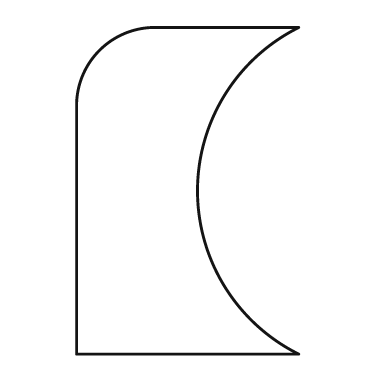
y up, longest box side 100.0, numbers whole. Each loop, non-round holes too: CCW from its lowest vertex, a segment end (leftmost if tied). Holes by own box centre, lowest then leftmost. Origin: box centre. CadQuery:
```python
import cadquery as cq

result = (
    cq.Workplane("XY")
    .moveTo(-34.0, -50.0)
    .lineTo(34.0, -50.0)
    .threePointArc((3.0, 0.0), (34.0, 50.0))
    .lineTo(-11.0, 50.0)
    .threePointArc((-27.0, 43.0), (-34.0, 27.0))
    .close()
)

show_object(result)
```